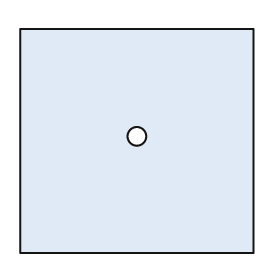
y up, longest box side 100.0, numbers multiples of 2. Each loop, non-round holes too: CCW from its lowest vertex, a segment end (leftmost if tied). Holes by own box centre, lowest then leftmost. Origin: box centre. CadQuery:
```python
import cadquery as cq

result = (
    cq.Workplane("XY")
    .moveTo(-50.0, -48.0)
    .lineTo(50.0, -48.0)
    .lineTo(50.0, 48.0)
    .lineTo(-50.0, 48.0)
    .close()
    .moveTo(0.0, 2.0)
    .circle(4.0)
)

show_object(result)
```